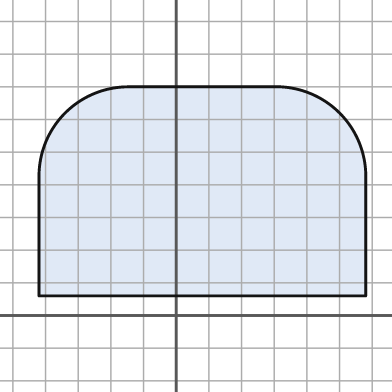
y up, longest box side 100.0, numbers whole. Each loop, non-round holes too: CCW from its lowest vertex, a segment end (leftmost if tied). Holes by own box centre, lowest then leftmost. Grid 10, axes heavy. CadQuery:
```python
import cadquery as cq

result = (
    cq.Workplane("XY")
    .moveTo(-42.0, 6.0)
    .lineTo(58.0, 6.0)
    .lineTo(58.0, 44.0)
    .threePointArc((50.0, 62.0), (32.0, 70.0))
    .lineTo(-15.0, 70.0)
    .threePointArc((-34.0, 62.0), (-42.0, 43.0))
    .close()
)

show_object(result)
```